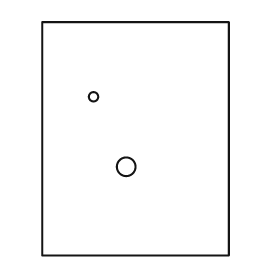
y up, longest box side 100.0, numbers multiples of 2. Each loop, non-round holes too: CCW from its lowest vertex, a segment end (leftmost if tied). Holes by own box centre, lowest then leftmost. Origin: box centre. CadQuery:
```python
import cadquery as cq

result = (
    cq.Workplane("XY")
    .moveTo(-40.0, -50.0)
    .lineTo(40.0, -50.0)
    .lineTo(40.0, 50.0)
    .lineTo(-40.0, 50.0)
    .close()
    .moveTo(-4.0, -12.0)
    .circle(4.0)
    .moveTo(-18.0, 18.0)
    .circle(2.0)
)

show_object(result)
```